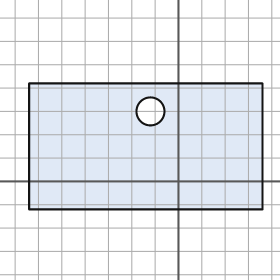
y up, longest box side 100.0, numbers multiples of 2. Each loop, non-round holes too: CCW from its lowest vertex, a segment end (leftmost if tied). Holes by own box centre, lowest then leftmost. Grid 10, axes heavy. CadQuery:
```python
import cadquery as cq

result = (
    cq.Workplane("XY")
    .moveTo(-64.0, -12.0)
    .lineTo(36.0, -12.0)
    .lineTo(36.0, 42.0)
    .lineTo(-64.0, 42.0)
    .close()
    .moveTo(-12.0, 30.0)
    .circle(6.0)
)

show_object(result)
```